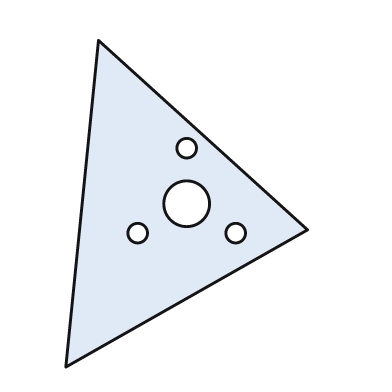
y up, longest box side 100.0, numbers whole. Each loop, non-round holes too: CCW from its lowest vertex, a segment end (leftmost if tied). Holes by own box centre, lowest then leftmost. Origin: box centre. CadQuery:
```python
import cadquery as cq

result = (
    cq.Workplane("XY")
    .moveTo(-37.0, -50.0)
    .lineTo(37.0, -8.0)
    .lineTo(-27.0, 50.0)
    .close()
    .moveTo(-15.0, -9.0)
    .circle(3.0)
    .moveTo(15.0, -9.0)
    .circle(3.0)
    .moveTo(0.0, 0.0)
    .circle(7.0)
    .moveTo(0.0, 17.0)
    .circle(3.0)
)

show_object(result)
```